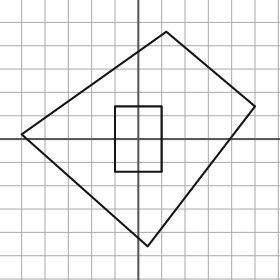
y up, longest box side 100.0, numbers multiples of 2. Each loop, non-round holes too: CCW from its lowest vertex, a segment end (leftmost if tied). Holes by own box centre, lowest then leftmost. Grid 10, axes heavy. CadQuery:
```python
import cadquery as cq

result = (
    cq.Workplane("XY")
    .moveTo(4.0, -46.0)
    .lineTo(50.0, 14.0)
    .lineTo(12.0, 46.0)
    .lineTo(-50.0, 2.0)
    .close()
    .moveTo(-10.0, -14.0)
    .lineTo(10.0, -14.0)
    .lineTo(10.0, 14.0)
    .lineTo(-10.0, 14.0)
    .close()
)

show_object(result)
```